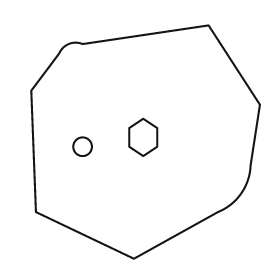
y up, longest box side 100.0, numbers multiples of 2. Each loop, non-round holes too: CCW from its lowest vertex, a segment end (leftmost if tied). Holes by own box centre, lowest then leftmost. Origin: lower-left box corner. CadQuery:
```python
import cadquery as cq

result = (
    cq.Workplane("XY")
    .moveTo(44.0, 0.0)
    .lineTo(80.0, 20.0)
    .threePointArc((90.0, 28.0), (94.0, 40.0))
    .lineTo(98.0, 66.0)
    .lineTo(76.0, 100.0)
    .lineTo(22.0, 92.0)
    .threePointArc((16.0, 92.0), (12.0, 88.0))
    .lineTo(0.0, 72.0)
    .lineTo(2.0, 20.0)
    .close()
    .moveTo(22.0, 48.0)
    .circle(4.0)
    .moveTo(48.0, 44.0)
    .lineTo(54.0, 48.0)
    .lineTo(54.0, 56.0)
    .lineTo(48.0, 60.0)
    .lineTo(42.0, 56.0)
    .lineTo(42.0, 48.0)
    .close()
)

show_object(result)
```